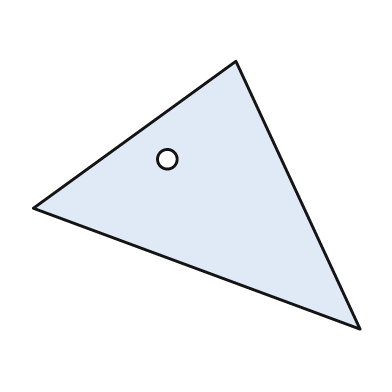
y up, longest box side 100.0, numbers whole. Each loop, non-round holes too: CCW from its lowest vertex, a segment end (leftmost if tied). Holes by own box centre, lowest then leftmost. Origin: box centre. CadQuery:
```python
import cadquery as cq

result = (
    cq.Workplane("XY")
    .moveTo(50.0, -41.0)
    .lineTo(12.0, 41.0)
    .lineTo(-50.0, -4.0)
    .close()
    .moveTo(-9.0, 11.0)
    .circle(3.0)
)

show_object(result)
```